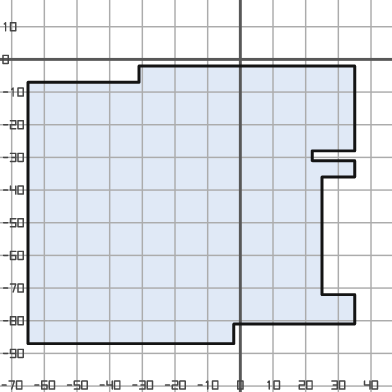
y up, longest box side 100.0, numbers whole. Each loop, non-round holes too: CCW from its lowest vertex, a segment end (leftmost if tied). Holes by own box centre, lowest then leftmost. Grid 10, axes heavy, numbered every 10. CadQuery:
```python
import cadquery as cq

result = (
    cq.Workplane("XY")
    .moveTo(-65.0, -87.0)
    .lineTo(-2.0, -87.0)
    .lineTo(-2.0, -81.0)
    .lineTo(35.0, -81.0)
    .lineTo(35.0, -72.0)
    .lineTo(25.0, -72.0)
    .lineTo(25.0, -36.0)
    .lineTo(35.0, -36.0)
    .lineTo(35.0, -31.0)
    .lineTo(22.0, -31.0)
    .lineTo(22.0, -28.0)
    .lineTo(35.0, -28.0)
    .lineTo(35.0, -2.0)
    .lineTo(-31.0, -2.0)
    .lineTo(-31.0, -7.0)
    .lineTo(-65.0, -7.0)
    .close()
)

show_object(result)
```